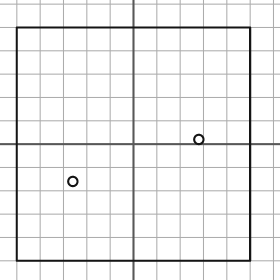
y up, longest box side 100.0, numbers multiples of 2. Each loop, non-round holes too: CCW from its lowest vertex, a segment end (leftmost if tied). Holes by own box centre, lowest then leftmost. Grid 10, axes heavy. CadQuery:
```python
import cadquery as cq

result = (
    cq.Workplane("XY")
    .moveTo(-50.0, -50.0)
    .lineTo(50.0, -50.0)
    .lineTo(50.0, 50.0)
    .lineTo(-50.0, 50.0)
    .close()
    .moveTo(-26.0, -16.0)
    .circle(2.0)
    .moveTo(28.0, 2.0)
    .circle(2.0)
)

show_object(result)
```